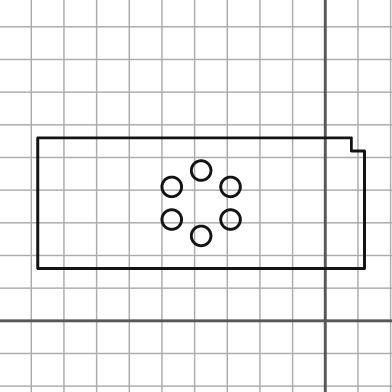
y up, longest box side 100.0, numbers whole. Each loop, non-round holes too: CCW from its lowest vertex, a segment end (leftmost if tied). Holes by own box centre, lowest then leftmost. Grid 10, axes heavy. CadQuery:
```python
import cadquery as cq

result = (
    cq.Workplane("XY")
    .moveTo(-88.0, 16.0)
    .lineTo(12.0, 16.0)
    .lineTo(12.0, 52.0)
    .lineTo(8.0, 52.0)
    .lineTo(8.0, 56.0)
    .lineTo(-88.0, 56.0)
    .close()
    .moveTo(-38.0, 26.0)
    .circle(3.0)
    .moveTo(-47.0, 31.0)
    .circle(3.0)
    .moveTo(-29.0, 31.0)
    .circle(3.0)
    .moveTo(-47.0, 41.0)
    .circle(3.0)
    .moveTo(-29.0, 41.0)
    .circle(3.0)
    .moveTo(-38.0, 46.0)
    .circle(3.0)
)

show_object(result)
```